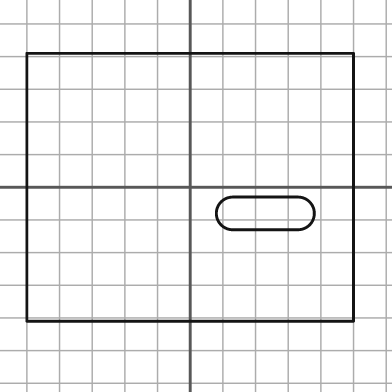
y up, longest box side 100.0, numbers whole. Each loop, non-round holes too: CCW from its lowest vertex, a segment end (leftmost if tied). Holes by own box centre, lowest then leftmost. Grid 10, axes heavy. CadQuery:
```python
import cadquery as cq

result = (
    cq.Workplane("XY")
    .moveTo(-50.0, -41.0)
    .lineTo(50.0, -41.0)
    .lineTo(50.0, 41.0)
    .lineTo(-50.0, 41.0)
    .close()
    .moveTo(13.0, -13.0)
    .lineTo(33.0, -13.0)
    .threePointArc((38.0, -8.0), (33.0, -3.0))
    .lineTo(13.0, -3.0)
    .threePointArc((8.0, -8.0), (13.0, -13.0))
    .close()
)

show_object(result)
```